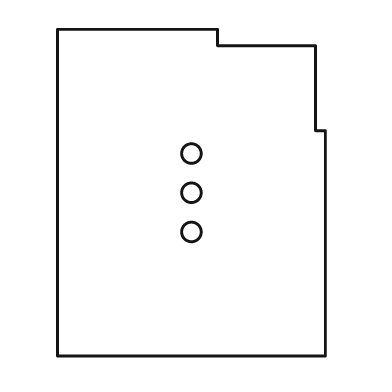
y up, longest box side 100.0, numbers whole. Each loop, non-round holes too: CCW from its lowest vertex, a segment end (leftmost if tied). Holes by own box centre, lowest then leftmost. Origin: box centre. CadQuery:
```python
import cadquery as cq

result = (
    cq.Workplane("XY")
    .moveTo(-41.0, -50.0)
    .lineTo(41.0, -50.0)
    .lineTo(41.0, 19.0)
    .lineTo(38.0, 19.0)
    .lineTo(38.0, 45.0)
    .lineTo(8.0, 45.0)
    .lineTo(8.0, 50.0)
    .lineTo(-41.0, 50.0)
    .close()
    .moveTo(0.0, -12.0)
    .circle(3.0)
    .moveTo(0.0, 0.0)
    .circle(3.0)
    .moveTo(0.0, 12.0)
    .circle(3.0)
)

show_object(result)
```